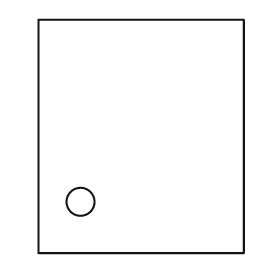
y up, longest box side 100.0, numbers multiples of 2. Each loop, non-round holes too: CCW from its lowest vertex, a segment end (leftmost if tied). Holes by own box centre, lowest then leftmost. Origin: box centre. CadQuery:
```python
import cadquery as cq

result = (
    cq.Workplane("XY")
    .moveTo(-44.0, -50.0)
    .lineTo(44.0, -50.0)
    .lineTo(44.0, 50.0)
    .lineTo(-44.0, 50.0)
    .close()
    .moveTo(-26.0, -28.0)
    .circle(6.0)
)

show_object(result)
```